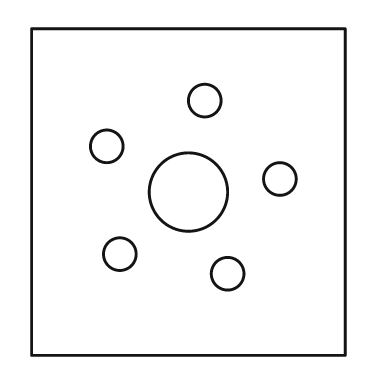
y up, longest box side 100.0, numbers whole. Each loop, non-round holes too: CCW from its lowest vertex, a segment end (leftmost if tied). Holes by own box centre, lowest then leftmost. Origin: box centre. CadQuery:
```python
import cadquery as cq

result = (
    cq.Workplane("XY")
    .moveTo(-48.0, -50.0)
    .lineTo(48.0, -50.0)
    .lineTo(48.0, 50.0)
    .lineTo(-48.0, 50.0)
    .close()
    .moveTo(12.0, -25.0)
    .circle(5.0)
    .moveTo(-21.0, -19.0)
    .circle(5.0)
    .moveTo(0.0, 0.0)
    .circle(12.0)
    .moveTo(28.0, 4.0)
    .circle(5.0)
    .moveTo(-25.0, 14.0)
    .circle(5.0)
    .moveTo(5.0, 28.0)
    .circle(5.0)
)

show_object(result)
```